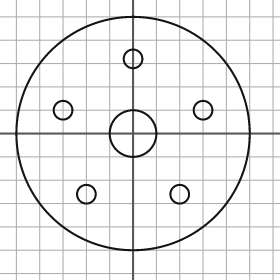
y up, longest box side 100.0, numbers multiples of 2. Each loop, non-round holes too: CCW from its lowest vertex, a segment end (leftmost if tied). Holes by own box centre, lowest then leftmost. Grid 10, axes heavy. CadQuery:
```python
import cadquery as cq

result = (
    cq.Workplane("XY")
    .moveTo(0.0, 0.0)
    .circle(50.0)
    .moveTo(-20.0, -26.0)
    .circle(4.0)
    .moveTo(20.0, -26.0)
    .circle(4.0)
    .moveTo(0.0, 0.0)
    .circle(10.0)
    .moveTo(-30.0, 10.0)
    .circle(4.0)
    .moveTo(30.0, 10.0)
    .circle(4.0)
    .moveTo(0.0, 32.0)
    .circle(4.0)
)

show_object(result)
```